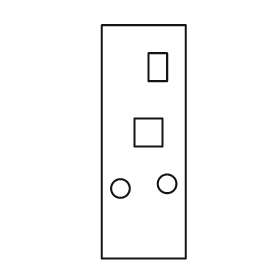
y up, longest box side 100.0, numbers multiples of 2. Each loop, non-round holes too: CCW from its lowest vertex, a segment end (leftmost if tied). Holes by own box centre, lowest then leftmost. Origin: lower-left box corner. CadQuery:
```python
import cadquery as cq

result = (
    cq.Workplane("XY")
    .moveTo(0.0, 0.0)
    .lineTo(36.0, 0.0)
    .lineTo(36.0, 100.0)
    .lineTo(0.0, 100.0)
    .close()
    .moveTo(8.0, 30.0)
    .circle(4.0)
    .moveTo(28.0, 32.0)
    .circle(4.0)
    .moveTo(14.0, 48.0)
    .lineTo(26.0, 48.0)
    .lineTo(26.0, 60.0)
    .lineTo(14.0, 60.0)
    .close()
    .moveTo(20.0, 76.0)
    .lineTo(28.0, 76.0)
    .lineTo(28.0, 88.0)
    .lineTo(20.0, 88.0)
    .close()
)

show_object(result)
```